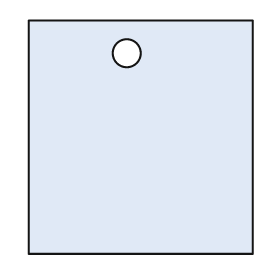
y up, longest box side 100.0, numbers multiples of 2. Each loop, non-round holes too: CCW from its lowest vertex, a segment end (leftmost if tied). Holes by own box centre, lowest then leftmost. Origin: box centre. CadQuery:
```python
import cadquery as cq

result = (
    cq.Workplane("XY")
    .moveTo(-48.0, -50.0)
    .lineTo(48.0, -50.0)
    .lineTo(48.0, 50.0)
    .lineTo(-48.0, 50.0)
    .close()
    .moveTo(-6.0, 36.0)
    .circle(6.0)
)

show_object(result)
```